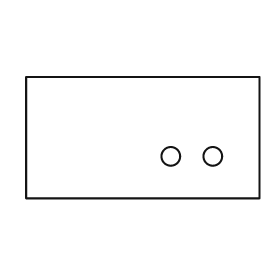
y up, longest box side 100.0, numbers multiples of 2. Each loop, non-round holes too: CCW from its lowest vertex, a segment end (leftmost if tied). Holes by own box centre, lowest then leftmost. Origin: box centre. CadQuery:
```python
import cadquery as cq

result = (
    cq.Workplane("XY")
    .moveTo(-50.0, -26.0)
    .lineTo(50.0, -26.0)
    .lineTo(50.0, 26.0)
    .lineTo(-50.0, 26.0)
    .close()
    .moveTo(12.0, -8.0)
    .circle(4.0)
    .moveTo(30.0, -8.0)
    .circle(4.0)
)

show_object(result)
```